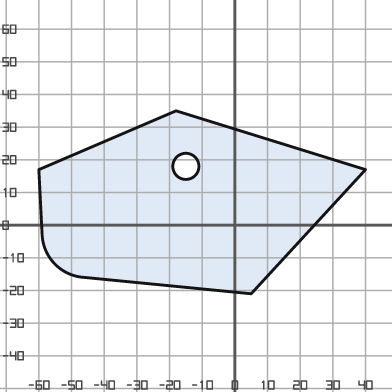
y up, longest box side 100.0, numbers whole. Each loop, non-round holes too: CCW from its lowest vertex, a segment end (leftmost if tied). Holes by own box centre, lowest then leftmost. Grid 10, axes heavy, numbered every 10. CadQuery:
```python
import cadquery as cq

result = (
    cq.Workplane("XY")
    .moveTo(5.0, -21.0)
    .lineTo(40.0, 17.0)
    .lineTo(-18.0, 35.0)
    .lineTo(-60.0, 17.0)
    .lineTo(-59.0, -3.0)
    .threePointArc((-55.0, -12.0), (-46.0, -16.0))
    .close()
    .moveTo(-15.0, 18.0)
    .circle(4.0)
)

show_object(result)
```